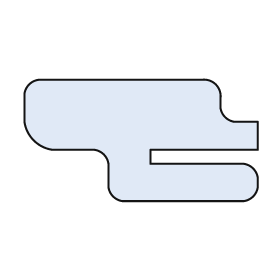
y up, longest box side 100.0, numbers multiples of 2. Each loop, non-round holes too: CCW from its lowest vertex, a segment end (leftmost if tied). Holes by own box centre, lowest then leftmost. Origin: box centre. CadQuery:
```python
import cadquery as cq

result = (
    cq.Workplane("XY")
    .moveTo(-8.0, -26.0)
    .lineTo(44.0, -26.0)
    .threePointArc((48.0, -24.0), (50.0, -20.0))
    .lineTo(50.0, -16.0)
    .threePointArc((48.0, -12.0), (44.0, -10.0))
    .lineTo(4.0, -10.0)
    .lineTo(4.0, -4.0)
    .lineTo(50.0, -4.0)
    .lineTo(50.0, 8.0)
    .lineTo(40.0, 8.0)
    .threePointArc((36.0, 10.0), (34.0, 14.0))
    .lineTo(34.0, 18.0)
    .threePointArc((32.0, 24.0), (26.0, 26.0))
    .lineTo(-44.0, 26.0)
    .threePointArc((-48.0, 24.0), (-50.0, 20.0))
    .lineTo(-50.0, 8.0)
    .threePointArc((-46.0, 0.0), (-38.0, -4.0))
    .lineTo(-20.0, -4.0)
    .threePointArc((-16.0, -6.0), (-14.0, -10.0))
    .lineTo(-14.0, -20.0)
    .threePointArc((-12.0, -24.0), (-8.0, -26.0))
    .close()
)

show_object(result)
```